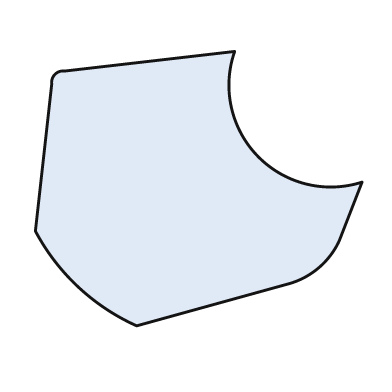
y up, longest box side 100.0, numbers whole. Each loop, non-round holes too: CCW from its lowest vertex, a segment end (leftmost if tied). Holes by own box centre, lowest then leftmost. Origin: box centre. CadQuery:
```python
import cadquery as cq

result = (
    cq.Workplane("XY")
    .moveTo(-19.0, -42.0)
    .lineTo(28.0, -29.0)
    .threePointArc((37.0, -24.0), (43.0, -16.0))
    .lineTo(50.0, 2.0)
    .threePointArc((18.0, 10.0), (11.0, 42.0))
    .lineTo(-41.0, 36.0)
    .threePointArc((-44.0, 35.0), (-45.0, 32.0))
    .lineTo(-50.0, -13.0)
    .threePointArc((-37.0, -30.0), (-19.0, -42.0))
    .close()
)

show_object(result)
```